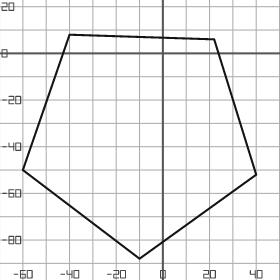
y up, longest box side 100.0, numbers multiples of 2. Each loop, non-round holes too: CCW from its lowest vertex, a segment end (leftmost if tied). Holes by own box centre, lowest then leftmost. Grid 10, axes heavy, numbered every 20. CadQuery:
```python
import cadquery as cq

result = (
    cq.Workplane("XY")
    .moveTo(-10.0, -88.0)
    .lineTo(40.0, -52.0)
    .lineTo(22.0, 6.0)
    .lineTo(-40.0, 8.0)
    .lineTo(-60.0, -50.0)
    .close()
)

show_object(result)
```